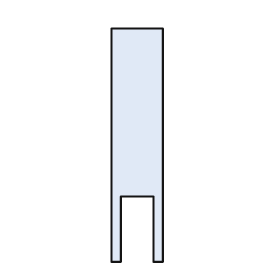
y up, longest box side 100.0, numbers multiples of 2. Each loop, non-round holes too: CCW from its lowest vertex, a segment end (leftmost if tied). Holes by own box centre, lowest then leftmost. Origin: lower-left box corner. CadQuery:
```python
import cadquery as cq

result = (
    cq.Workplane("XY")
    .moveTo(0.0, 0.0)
    .lineTo(4.0, 0.0)
    .lineTo(4.0, 28.0)
    .lineTo(18.0, 28.0)
    .lineTo(18.0, 0.0)
    .lineTo(22.0, 0.0)
    .lineTo(22.0, 100.0)
    .lineTo(0.0, 100.0)
    .close()
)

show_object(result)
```